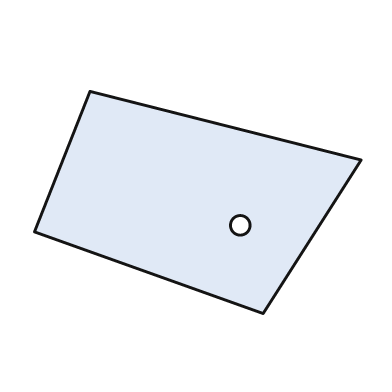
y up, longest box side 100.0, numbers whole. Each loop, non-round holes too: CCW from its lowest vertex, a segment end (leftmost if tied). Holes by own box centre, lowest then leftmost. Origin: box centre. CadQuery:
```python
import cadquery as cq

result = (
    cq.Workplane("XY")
    .moveTo(20.0, -34.0)
    .lineTo(50.0, 13.0)
    .lineTo(-33.0, 34.0)
    .lineTo(-50.0, -9.0)
    .close()
    .moveTo(13.0, -7.0)
    .circle(3.0)
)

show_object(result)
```